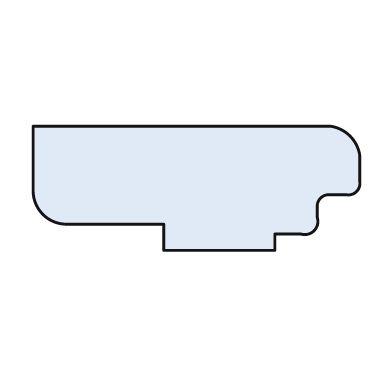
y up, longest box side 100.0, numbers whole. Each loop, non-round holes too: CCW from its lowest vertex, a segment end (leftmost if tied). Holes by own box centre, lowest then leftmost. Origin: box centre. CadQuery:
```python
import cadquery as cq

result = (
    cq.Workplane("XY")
    .moveTo(-10.0, -19.0)
    .lineTo(24.0, -19.0)
    .lineTo(24.0, -14.0)
    .lineTo(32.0, -14.0)
    .threePointArc((36.0, -13.0), (37.0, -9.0))
    .lineTo(37.0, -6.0)
    .threePointArc((38.0, -3.0), (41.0, -2.0))
    .lineTo(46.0, -2.0)
    .threePointArc((49.0, -1.0), (50.0, 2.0))
    .lineTo(50.0, 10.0)
    .threePointArc((47.0, 16.0), (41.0, 19.0))
    .lineTo(-50.0, 19.0)
    .lineTo(-50.0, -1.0)
    .threePointArc((-47.0, -8.0), (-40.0, -11.0))
    .lineTo(-10.0, -11.0)
    .close()
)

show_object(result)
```